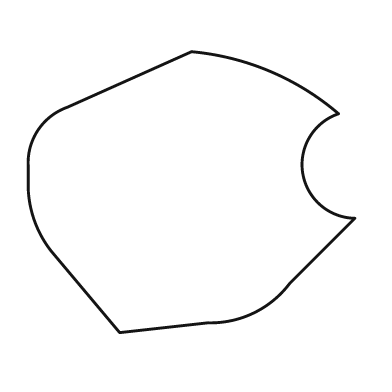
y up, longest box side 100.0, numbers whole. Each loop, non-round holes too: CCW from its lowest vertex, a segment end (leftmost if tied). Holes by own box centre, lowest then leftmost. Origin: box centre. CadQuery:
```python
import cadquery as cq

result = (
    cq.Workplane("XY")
    .moveTo(-22.0, -43.0)
    .lineTo(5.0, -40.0)
    .threePointArc((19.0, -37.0), (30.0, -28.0))
    .lineTo(50.0, -8.0)
    .threePointArc((34.0, 6.0), (45.0, 24.0))
    .threePointArc((24.0, 37.0), (0.0, 43.0))
    .lineTo(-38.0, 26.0)
    .threePointArc((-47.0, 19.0), (-50.0, 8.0))
    .lineTo(-50.0, 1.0)
    .threePointArc((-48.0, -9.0), (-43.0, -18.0))
    .close()
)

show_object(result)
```